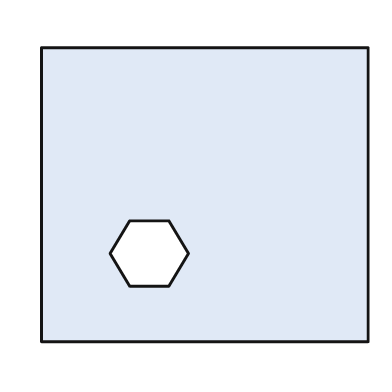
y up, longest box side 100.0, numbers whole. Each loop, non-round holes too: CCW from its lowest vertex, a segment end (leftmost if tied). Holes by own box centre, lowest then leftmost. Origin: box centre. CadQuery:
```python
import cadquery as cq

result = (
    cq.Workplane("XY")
    .moveTo(-50.0, -45.0)
    .lineTo(50.0, -45.0)
    .lineTo(50.0, 45.0)
    .lineTo(-50.0, 45.0)
    .close()
    .moveTo(-23.0, -28.0)
    .lineTo(-11.0, -28.0)
    .lineTo(-5.0, -18.0)
    .lineTo(-11.0, -8.0)
    .lineTo(-23.0, -8.0)
    .lineTo(-29.0, -18.0)
    .close()
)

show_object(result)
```